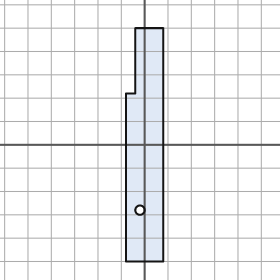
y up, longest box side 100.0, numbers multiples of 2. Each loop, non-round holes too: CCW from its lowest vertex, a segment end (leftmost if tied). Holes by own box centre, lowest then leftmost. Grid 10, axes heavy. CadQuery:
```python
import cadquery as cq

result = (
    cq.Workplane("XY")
    .moveTo(-8.0, -50.0)
    .lineTo(8.0, -50.0)
    .lineTo(8.0, 50.0)
    .lineTo(-4.0, 50.0)
    .lineTo(-4.0, 22.0)
    .lineTo(-8.0, 22.0)
    .close()
    .moveTo(-2.0, -28.0)
    .circle(2.0)
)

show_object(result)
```